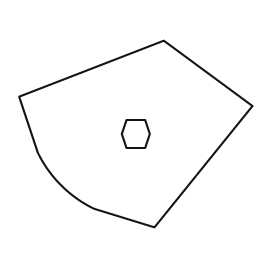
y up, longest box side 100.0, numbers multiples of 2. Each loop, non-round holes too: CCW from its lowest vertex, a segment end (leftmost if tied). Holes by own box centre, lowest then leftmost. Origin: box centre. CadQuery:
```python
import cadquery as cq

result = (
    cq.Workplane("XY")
    .moveTo(8.0, -40.0)
    .lineTo(50.0, 12.0)
    .lineTo(12.0, 40.0)
    .lineTo(-50.0, 16.0)
    .lineTo(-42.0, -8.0)
    .threePointArc((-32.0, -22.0), (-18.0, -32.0))
    .close()
    .moveTo(-4.0, -6.0)
    .lineTo(4.0, -6.0)
    .lineTo(6.0, 0.0)
    .lineTo(4.0, 6.0)
    .lineTo(-4.0, 6.0)
    .lineTo(-6.0, 0.0)
    .close()
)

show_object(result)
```